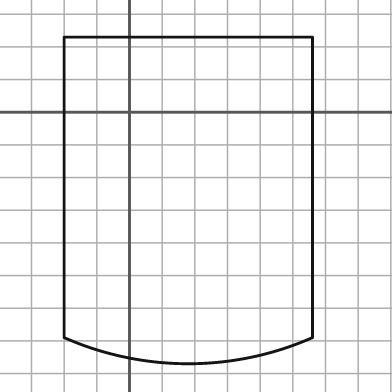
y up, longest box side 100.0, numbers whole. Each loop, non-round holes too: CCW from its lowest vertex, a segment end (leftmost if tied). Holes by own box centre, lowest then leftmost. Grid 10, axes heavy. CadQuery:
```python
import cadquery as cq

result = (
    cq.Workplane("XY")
    .moveTo(-20.0, -69.0)
    .threePointArc((18.0, -77.0), (56.0, -69.0))
    .lineTo(56.0, 23.0)
    .lineTo(-20.0, 23.0)
    .close()
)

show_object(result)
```